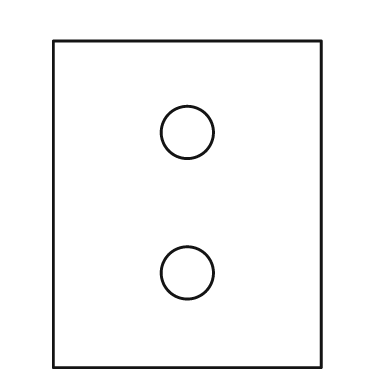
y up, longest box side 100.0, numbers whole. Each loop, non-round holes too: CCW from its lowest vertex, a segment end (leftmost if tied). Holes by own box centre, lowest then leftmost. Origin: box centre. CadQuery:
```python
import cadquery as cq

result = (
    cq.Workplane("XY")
    .moveTo(-41.0, -50.0)
    .lineTo(41.0, -50.0)
    .lineTo(41.0, 50.0)
    .lineTo(-41.0, 50.0)
    .close()
    .moveTo(0.0, -21.0)
    .circle(8.0)
    .moveTo(0.0, 22.0)
    .circle(8.0)
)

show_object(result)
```